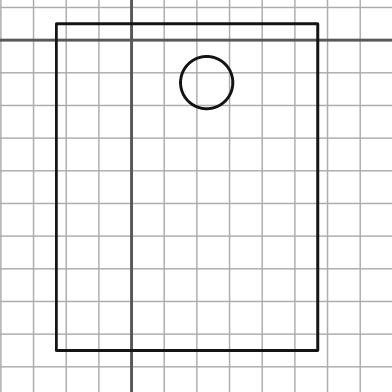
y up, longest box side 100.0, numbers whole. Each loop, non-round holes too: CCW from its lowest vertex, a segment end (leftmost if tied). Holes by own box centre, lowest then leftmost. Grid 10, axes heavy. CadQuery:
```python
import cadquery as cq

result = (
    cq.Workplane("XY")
    .moveTo(-23.0, -95.0)
    .lineTo(57.0, -95.0)
    .lineTo(57.0, 5.0)
    .lineTo(-23.0, 5.0)
    .close()
    .moveTo(23.0, -13.0)
    .circle(8.0)
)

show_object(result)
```